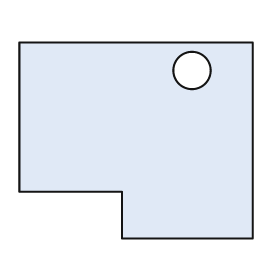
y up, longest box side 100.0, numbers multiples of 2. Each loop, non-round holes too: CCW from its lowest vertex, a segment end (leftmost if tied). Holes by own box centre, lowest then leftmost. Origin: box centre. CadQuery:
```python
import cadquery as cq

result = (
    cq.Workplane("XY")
    .moveTo(-6.0, -42.0)
    .lineTo(50.0, -42.0)
    .lineTo(50.0, 42.0)
    .lineTo(-50.0, 42.0)
    .lineTo(-50.0, -22.0)
    .lineTo(-6.0, -22.0)
    .close()
    .moveTo(24.0, 30.0)
    .circle(8.0)
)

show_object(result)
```